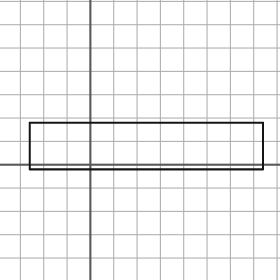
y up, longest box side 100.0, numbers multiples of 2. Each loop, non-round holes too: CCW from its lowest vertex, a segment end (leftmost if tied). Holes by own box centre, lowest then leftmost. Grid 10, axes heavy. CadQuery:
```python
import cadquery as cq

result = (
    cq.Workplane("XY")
    .moveTo(-26.0, -2.0)
    .lineTo(74.0, -2.0)
    .lineTo(74.0, 18.0)
    .lineTo(-26.0, 18.0)
    .close()
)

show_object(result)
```